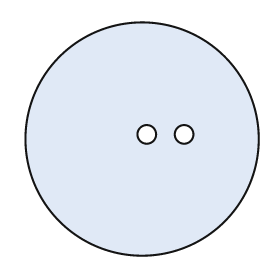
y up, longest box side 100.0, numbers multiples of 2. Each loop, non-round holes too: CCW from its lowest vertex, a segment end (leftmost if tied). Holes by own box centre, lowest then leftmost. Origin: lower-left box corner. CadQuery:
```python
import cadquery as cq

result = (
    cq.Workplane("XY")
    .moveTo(50.0, 50.0)
    .circle(50.0)
    .moveTo(52.0, 52.0)
    .circle(4.0)
    .moveTo(68.0, 52.0)
    .circle(4.0)
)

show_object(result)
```